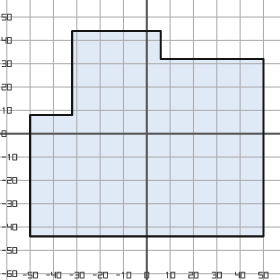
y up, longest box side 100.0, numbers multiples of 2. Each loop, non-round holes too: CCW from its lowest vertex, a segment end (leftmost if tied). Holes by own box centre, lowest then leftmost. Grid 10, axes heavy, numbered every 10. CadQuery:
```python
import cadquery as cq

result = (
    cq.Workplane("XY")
    .moveTo(-50.0, -44.0)
    .lineTo(50.0, -44.0)
    .lineTo(50.0, 32.0)
    .lineTo(6.0, 32.0)
    .lineTo(6.0, 44.0)
    .lineTo(-32.0, 44.0)
    .lineTo(-32.0, 8.0)
    .lineTo(-50.0, 8.0)
    .close()
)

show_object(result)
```